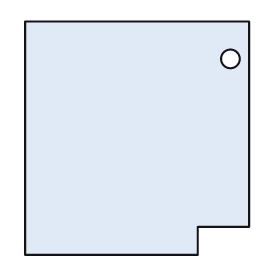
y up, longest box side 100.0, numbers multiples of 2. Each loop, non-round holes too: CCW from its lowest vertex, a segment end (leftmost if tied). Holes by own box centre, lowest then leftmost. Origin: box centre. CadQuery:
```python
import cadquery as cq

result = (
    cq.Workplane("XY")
    .moveTo(-48.0, -50.0)
    .lineTo(26.0, -50.0)
    .lineTo(26.0, -38.0)
    .lineTo(48.0, -38.0)
    .lineTo(48.0, 50.0)
    .lineTo(-48.0, 50.0)
    .close()
    .moveTo(40.0, 34.0)
    .circle(4.0)
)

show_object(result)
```